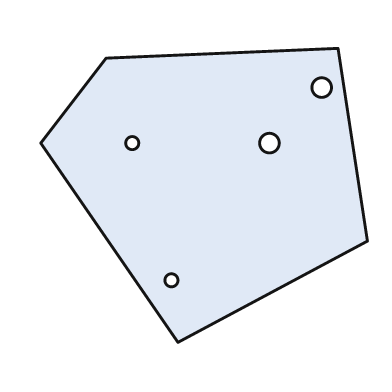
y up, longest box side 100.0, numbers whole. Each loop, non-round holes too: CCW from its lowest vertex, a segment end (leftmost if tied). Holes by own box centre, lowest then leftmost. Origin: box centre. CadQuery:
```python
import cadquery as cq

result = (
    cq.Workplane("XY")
    .moveTo(-8.0, -45.0)
    .lineTo(50.0, -14.0)
    .lineTo(41.0, 45.0)
    .lineTo(-30.0, 42.0)
    .lineTo(-50.0, 16.0)
    .close()
    .moveTo(-10.0, -26.0)
    .circle(2.0)
    .moveTo(-22.0, 16.0)
    .circle(2.0)
    .moveTo(20.0, 16.0)
    .circle(3.0)
    .moveTo(36.0, 33.0)
    .circle(3.0)
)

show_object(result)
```